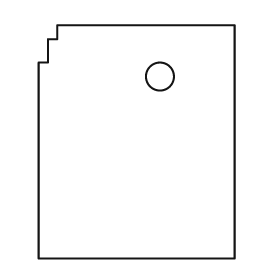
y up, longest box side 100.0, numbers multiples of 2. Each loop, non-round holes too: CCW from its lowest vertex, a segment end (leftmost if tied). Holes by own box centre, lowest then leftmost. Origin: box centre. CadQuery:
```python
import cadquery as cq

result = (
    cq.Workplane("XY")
    .moveTo(-42.0, -50.0)
    .lineTo(42.0, -50.0)
    .lineTo(42.0, 50.0)
    .lineTo(-34.0, 50.0)
    .lineTo(-34.0, 44.0)
    .lineTo(-38.0, 44.0)
    .lineTo(-38.0, 34.0)
    .lineTo(-42.0, 34.0)
    .close()
    .moveTo(10.0, 28.0)
    .circle(6.0)
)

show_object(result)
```